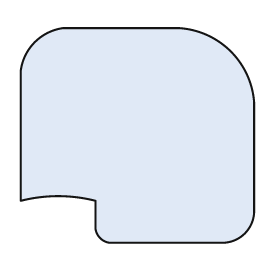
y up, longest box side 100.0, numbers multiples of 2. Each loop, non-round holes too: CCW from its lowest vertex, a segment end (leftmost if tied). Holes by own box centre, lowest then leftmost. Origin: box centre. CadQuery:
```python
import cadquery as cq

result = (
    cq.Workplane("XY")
    .moveTo(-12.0, -46.0)
    .lineTo(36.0, -46.0)
    .threePointArc((46.0, -42.0), (50.0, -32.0))
    .lineTo(50.0, 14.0)
    .threePointArc((40.0, 36.0), (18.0, 46.0))
    .lineTo(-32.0, 46.0)
    .threePointArc((-44.0, 40.0), (-50.0, 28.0))
    .lineTo(-50.0, -28.0)
    .threePointArc((-34.0, -26.0), (-18.0, -28.0))
    .lineTo(-18.0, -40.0)
    .threePointArc((-16.0, -44.0), (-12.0, -46.0))
    .close()
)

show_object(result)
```